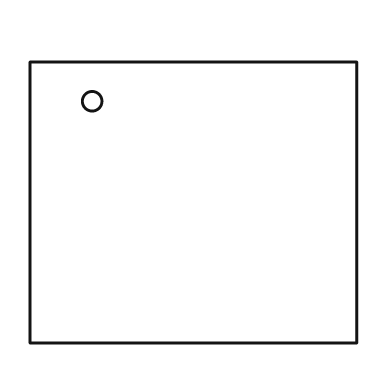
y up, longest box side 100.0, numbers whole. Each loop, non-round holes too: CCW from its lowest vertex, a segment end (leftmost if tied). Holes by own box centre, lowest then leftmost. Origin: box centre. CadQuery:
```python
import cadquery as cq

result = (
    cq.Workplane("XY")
    .moveTo(-50.0, -43.0)
    .lineTo(50.0, -43.0)
    .lineTo(50.0, 43.0)
    .lineTo(-50.0, 43.0)
    .close()
    .moveTo(-31.0, 31.0)
    .circle(3.0)
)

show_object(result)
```